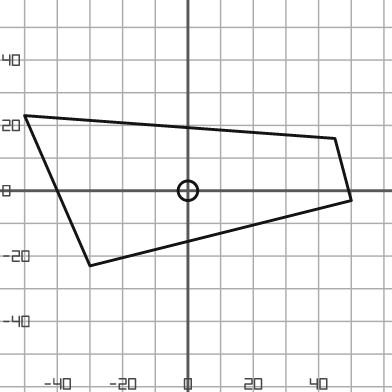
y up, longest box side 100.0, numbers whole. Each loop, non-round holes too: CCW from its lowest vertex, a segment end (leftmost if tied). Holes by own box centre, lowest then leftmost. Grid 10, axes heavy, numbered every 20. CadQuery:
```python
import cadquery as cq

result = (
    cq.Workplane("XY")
    .moveTo(-30.0, -23.0)
    .lineTo(50.0, -3.0)
    .lineTo(45.0, 16.0)
    .lineTo(-50.0, 23.0)
    .close()
    .moveTo(0.0, 0.0)
    .circle(3.0)
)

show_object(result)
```